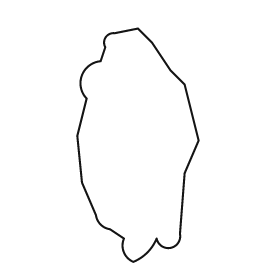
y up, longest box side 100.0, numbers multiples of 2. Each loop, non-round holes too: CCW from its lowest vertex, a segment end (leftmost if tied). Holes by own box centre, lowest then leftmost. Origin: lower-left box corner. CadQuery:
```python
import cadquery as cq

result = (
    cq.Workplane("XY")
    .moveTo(24.0, 0.0)
    .threePointArc((30.0, 4.0), (34.0, 10.0))
    .threePointArc((40.0, 6.0), (44.0, 12.0))
    .lineTo(46.0, 38.0)
    .lineTo(52.0, 52.0)
    .lineTo(46.0, 76.0)
    .lineTo(40.0, 82.0)
    .lineTo(32.0, 94.0)
    .lineTo(26.0, 100.0)
    .lineTo(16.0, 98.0)
    .threePointArc((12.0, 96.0), (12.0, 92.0))
    .lineTo(10.0, 86.0)
    .threePointArc((2.0, 80.0), (4.0, 70.0))
    .lineTo(0.0, 54.0)
    .lineTo(2.0, 34.0)
    .lineTo(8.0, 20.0)
    .threePointArc((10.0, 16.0), (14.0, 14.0))
    .lineTo(20.0, 10.0)
    .threePointArc((20.0, 4.0), (24.0, 0.0))
    .close()
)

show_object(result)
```